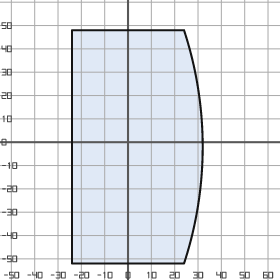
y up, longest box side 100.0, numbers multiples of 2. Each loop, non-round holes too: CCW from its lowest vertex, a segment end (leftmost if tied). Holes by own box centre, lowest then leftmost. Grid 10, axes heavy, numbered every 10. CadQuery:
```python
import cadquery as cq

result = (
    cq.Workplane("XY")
    .moveTo(-24.0, -52.0)
    .lineTo(24.0, -52.0)
    .threePointArc((32.0, -2.0), (24.0, 48.0))
    .lineTo(-24.0, 48.0)
    .close()
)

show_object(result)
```